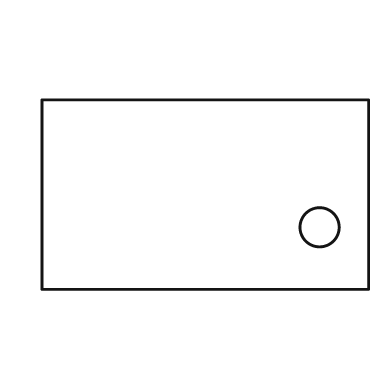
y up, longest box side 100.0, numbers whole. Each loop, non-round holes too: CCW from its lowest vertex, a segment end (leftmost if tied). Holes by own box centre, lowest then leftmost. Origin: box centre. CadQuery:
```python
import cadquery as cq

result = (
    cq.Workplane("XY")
    .moveTo(-50.0, -29.0)
    .lineTo(50.0, -29.0)
    .lineTo(50.0, 29.0)
    .lineTo(-50.0, 29.0)
    .close()
    .moveTo(35.0, -10.0)
    .circle(6.0)
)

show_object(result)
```